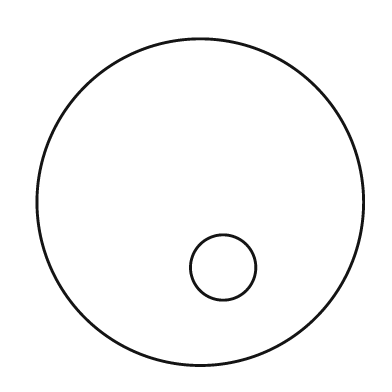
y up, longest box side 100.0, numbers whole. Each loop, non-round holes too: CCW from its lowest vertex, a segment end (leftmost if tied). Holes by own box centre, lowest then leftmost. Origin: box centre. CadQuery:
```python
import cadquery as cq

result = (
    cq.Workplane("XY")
    .moveTo(0.0, 0.0)
    .circle(50.0)
    .moveTo(7.0, -20.0)
    .circle(10.0)
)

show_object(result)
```